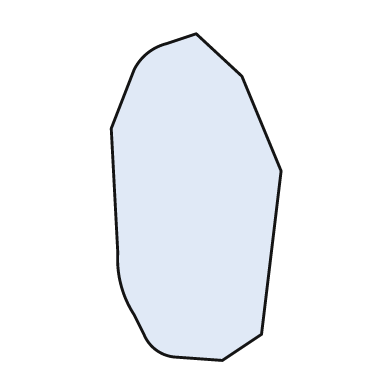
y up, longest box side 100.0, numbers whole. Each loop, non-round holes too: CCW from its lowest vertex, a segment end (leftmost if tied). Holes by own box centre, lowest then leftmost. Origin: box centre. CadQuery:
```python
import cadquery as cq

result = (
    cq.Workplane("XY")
    .moveTo(8.0, -50.0)
    .lineTo(20.0, -42.0)
    .lineTo(26.0, 8.0)
    .lineTo(14.0, 37.0)
    .lineTo(0.0, 50.0)
    .lineTo(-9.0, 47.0)
    .threePointArc((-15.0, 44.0), (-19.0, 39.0))
    .lineTo(-26.0, 21.0)
    .lineTo(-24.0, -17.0)
    .threePointArc((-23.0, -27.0), (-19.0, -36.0))
    .lineTo(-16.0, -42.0)
    .threePointArc((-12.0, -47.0), (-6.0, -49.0))
    .close()
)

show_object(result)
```